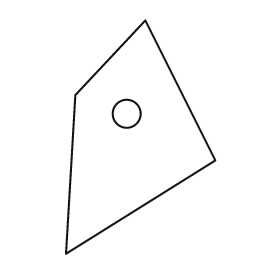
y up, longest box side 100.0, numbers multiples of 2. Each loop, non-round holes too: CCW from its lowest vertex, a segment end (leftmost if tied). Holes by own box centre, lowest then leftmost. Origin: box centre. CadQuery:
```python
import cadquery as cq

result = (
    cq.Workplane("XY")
    .moveTo(-32.0, -50.0)
    .lineTo(32.0, -10.0)
    .lineTo(2.0, 50.0)
    .lineTo(-28.0, 18.0)
    .close()
    .moveTo(-6.0, 10.0)
    .circle(6.0)
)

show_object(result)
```